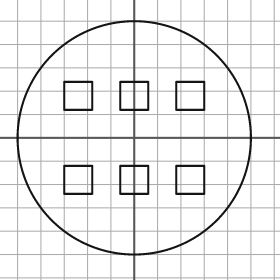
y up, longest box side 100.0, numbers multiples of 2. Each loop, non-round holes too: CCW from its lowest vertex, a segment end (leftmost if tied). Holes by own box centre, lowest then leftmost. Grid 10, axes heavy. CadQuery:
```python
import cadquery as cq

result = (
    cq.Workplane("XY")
    .moveTo(0.0, 0.0)
    .circle(50.0)
    .moveTo(-30.0, -24.0)
    .lineTo(-18.0, -24.0)
    .lineTo(-18.0, -12.0)
    .lineTo(-30.0, -12.0)
    .close()
    .moveTo(-6.0, -24.0)
    .lineTo(6.0, -24.0)
    .lineTo(6.0, -12.0)
    .lineTo(-6.0, -12.0)
    .close()
    .moveTo(18.0, -24.0)
    .lineTo(30.0, -24.0)
    .lineTo(30.0, -12.0)
    .lineTo(18.0, -12.0)
    .close()
    .moveTo(-30.0, 12.0)
    .lineTo(-18.0, 12.0)
    .lineTo(-18.0, 24.0)
    .lineTo(-30.0, 24.0)
    .close()
    .moveTo(-6.0, 12.0)
    .lineTo(6.0, 12.0)
    .lineTo(6.0, 24.0)
    .lineTo(-6.0, 24.0)
    .close()
    .moveTo(18.0, 12.0)
    .lineTo(30.0, 12.0)
    .lineTo(30.0, 24.0)
    .lineTo(18.0, 24.0)
    .close()
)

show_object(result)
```